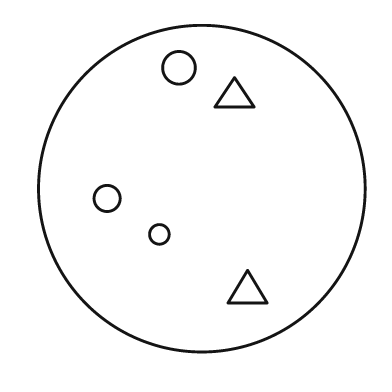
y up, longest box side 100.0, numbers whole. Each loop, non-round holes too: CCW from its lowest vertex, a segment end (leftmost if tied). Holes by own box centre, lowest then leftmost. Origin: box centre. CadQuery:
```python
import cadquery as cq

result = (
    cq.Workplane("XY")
    .moveTo(0.0, 0.0)
    .circle(50.0)
    .moveTo(8.0, -35.0)
    .lineTo(20.0, -35.0)
    .lineTo(14.0, -25.0)
    .close()
    .moveTo(-13.0, -14.0)
    .circle(3.0)
    .moveTo(-29.0, -3.0)
    .circle(4.0)
    .moveTo(4.0, 25.0)
    .lineTo(16.0, 25.0)
    .lineTo(10.0, 34.0)
    .close()
    .moveTo(-7.0, 37.0)
    .circle(5.0)
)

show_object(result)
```